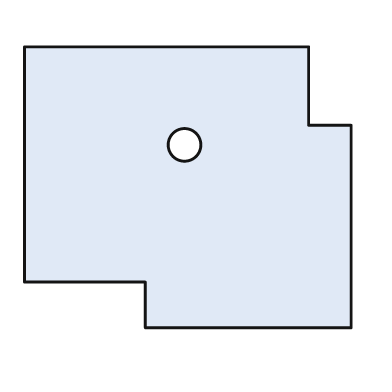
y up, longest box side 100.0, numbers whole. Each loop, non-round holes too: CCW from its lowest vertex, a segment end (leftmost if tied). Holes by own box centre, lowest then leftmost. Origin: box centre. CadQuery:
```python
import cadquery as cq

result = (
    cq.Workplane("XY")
    .moveTo(-13.0, -43.0)
    .lineTo(50.0, -43.0)
    .lineTo(50.0, 19.0)
    .lineTo(37.0, 19.0)
    .lineTo(37.0, 43.0)
    .lineTo(-50.0, 43.0)
    .lineTo(-50.0, -29.0)
    .lineTo(-13.0, -29.0)
    .close()
    .moveTo(-1.0, 13.0)
    .circle(5.0)
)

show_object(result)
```